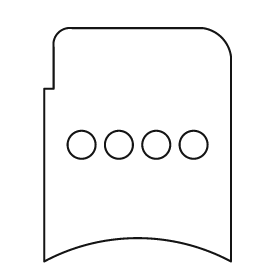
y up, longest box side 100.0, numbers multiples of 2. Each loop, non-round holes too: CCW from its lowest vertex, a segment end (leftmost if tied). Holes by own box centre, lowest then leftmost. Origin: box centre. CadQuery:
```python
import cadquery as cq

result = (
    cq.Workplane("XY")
    .moveTo(-40.0, -50.0)
    .threePointArc((0.0, -40.0), (40.0, -50.0))
    .lineTo(40.0, 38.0)
    .threePointArc((36.0, 46.0), (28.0, 50.0))
    .lineTo(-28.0, 50.0)
    .threePointArc((-34.0, 48.0), (-36.0, 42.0))
    .lineTo(-36.0, 24.0)
    .lineTo(-40.0, 24.0)
    .close()
    .moveTo(-24.0, 0.0)
    .circle(6.0)
    .moveTo(-8.0, 0.0)
    .circle(6.0)
    .moveTo(8.0, 0.0)
    .circle(6.0)
    .moveTo(24.0, 0.0)
    .circle(6.0)
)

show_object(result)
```